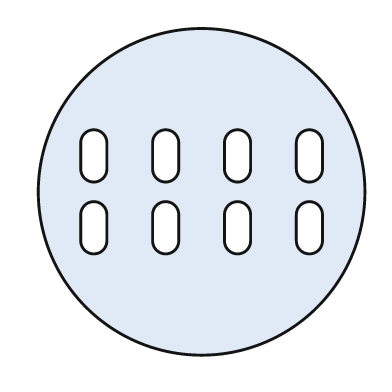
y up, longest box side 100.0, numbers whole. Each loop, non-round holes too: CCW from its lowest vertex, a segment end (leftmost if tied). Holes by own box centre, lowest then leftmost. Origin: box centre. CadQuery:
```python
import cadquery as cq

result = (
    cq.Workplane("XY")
    .moveTo(0.0, 0.0)
    .circle(50.0)
    .moveTo(-37.0, -15.0)
    .threePointArc((-33.0, -19.0), (-29.0, -15.0))
    .lineTo(-29.0, -7.0)
    .threePointArc((-33.0, -3.0), (-37.0, -7.0))
    .close()
    .moveTo(-15.0, -15.0)
    .threePointArc((-11.0, -19.0), (-7.0, -15.0))
    .lineTo(-7.0, -7.0)
    .threePointArc((-11.0, -3.0), (-15.0, -7.0))
    .close()
    .moveTo(7.0, -15.0)
    .threePointArc((11.0, -19.0), (15.0, -15.0))
    .lineTo(15.0, -7.0)
    .threePointArc((11.0, -3.0), (7.0, -7.0))
    .close()
    .moveTo(29.0, -15.0)
    .threePointArc((33.0, -19.0), (37.0, -15.0))
    .lineTo(37.0, -7.0)
    .threePointArc((33.0, -3.0), (29.0, -7.0))
    .close()
    .moveTo(-37.0, 7.0)
    .threePointArc((-33.0, 3.0), (-29.0, 7.0))
    .lineTo(-29.0, 15.0)
    .threePointArc((-33.0, 19.0), (-37.0, 15.0))
    .close()
    .moveTo(-15.0, 7.0)
    .threePointArc((-11.0, 3.0), (-7.0, 7.0))
    .lineTo(-7.0, 15.0)
    .threePointArc((-11.0, 19.0), (-15.0, 15.0))
    .close()
    .moveTo(7.0, 7.0)
    .threePointArc((11.0, 3.0), (15.0, 7.0))
    .lineTo(15.0, 15.0)
    .threePointArc((11.0, 19.0), (7.0, 15.0))
    .close()
    .moveTo(29.0, 7.0)
    .threePointArc((33.0, 3.0), (37.0, 7.0))
    .lineTo(37.0, 15.0)
    .threePointArc((33.0, 19.0), (29.0, 15.0))
    .close()
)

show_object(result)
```